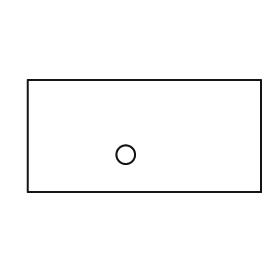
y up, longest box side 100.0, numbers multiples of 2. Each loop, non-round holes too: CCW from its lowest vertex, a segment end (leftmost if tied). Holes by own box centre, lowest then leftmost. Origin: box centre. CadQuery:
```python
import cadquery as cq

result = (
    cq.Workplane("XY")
    .moveTo(-50.0, -24.0)
    .lineTo(50.0, -24.0)
    .lineTo(50.0, 24.0)
    .lineTo(-50.0, 24.0)
    .close()
    .moveTo(-8.0, -8.0)
    .circle(4.0)
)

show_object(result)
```